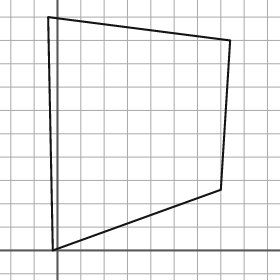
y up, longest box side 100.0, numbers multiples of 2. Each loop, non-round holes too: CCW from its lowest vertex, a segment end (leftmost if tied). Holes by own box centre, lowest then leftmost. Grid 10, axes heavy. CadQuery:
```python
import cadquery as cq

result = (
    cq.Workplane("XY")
    .moveTo(-2.0, 0.0)
    .lineTo(70.0, 26.0)
    .lineTo(74.0, 90.0)
    .lineTo(-4.0, 100.0)
    .close()
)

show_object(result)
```